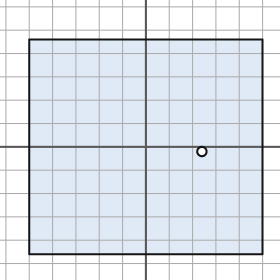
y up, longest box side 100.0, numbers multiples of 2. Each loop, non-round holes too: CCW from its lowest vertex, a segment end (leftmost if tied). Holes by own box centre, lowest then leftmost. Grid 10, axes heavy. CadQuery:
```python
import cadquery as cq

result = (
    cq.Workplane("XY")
    .moveTo(-50.0, -46.0)
    .lineTo(50.0, -46.0)
    .lineTo(50.0, 46.0)
    .lineTo(-50.0, 46.0)
    .close()
    .moveTo(24.0, -2.0)
    .circle(2.0)
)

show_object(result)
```